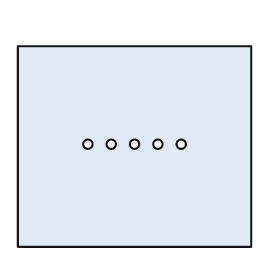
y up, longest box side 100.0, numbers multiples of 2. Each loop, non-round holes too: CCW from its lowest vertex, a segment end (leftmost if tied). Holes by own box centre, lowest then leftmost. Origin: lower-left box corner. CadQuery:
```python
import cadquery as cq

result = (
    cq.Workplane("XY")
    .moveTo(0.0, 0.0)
    .lineTo(100.0, 0.0)
    .lineTo(100.0, 86.0)
    .lineTo(0.0, 86.0)
    .close()
    .moveTo(30.0, 44.0)
    .circle(2.0)
    .moveTo(40.0, 44.0)
    .circle(2.0)
    .moveTo(50.0, 44.0)
    .circle(2.0)
    .moveTo(60.0, 44.0)
    .circle(2.0)
    .moveTo(70.0, 44.0)
    .circle(2.0)
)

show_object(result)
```